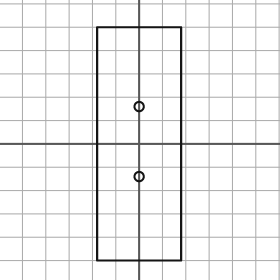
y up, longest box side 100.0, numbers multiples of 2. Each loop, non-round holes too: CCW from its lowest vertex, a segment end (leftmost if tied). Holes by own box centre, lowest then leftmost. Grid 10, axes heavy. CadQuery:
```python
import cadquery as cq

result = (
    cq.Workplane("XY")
    .moveTo(-18.0, -50.0)
    .lineTo(18.0, -50.0)
    .lineTo(18.0, 50.0)
    .lineTo(-18.0, 50.0)
    .close()
    .moveTo(0.0, -14.0)
    .circle(2.0)
    .moveTo(0.0, 16.0)
    .circle(2.0)
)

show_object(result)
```